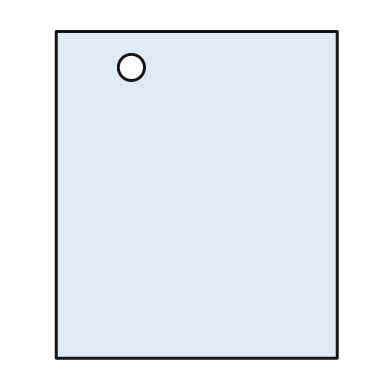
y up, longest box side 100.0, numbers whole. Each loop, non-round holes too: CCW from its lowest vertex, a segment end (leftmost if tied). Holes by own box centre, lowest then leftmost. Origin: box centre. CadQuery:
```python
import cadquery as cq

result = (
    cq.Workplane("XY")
    .moveTo(-43.0, -50.0)
    .lineTo(43.0, -50.0)
    .lineTo(43.0, 50.0)
    .lineTo(-43.0, 50.0)
    .close()
    .moveTo(-20.0, 39.0)
    .circle(4.0)
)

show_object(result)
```